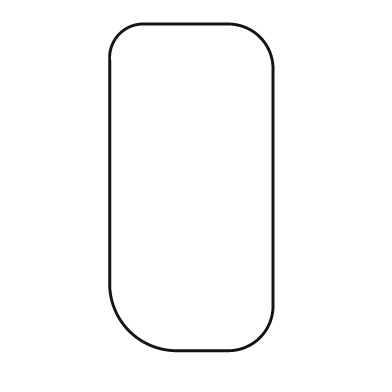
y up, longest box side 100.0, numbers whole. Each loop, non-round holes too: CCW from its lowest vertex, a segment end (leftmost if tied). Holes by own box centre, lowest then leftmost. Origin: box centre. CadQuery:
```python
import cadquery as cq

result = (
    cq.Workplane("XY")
    .moveTo(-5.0, -50.0)
    .lineTo(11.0, -50.0)
    .threePointArc((21.0, -46.0), (25.0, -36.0))
    .lineTo(25.0, 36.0)
    .threePointArc((21.0, 46.0), (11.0, 50.0))
    .lineTo(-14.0, 50.0)
    .threePointArc((-22.0, 47.0), (-25.0, 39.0))
    .lineTo(-25.0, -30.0)
    .threePointArc((-19.0, -44.0), (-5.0, -50.0))
    .close()
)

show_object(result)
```